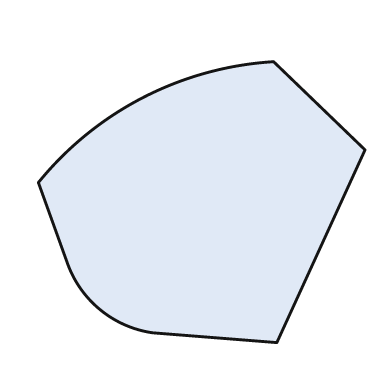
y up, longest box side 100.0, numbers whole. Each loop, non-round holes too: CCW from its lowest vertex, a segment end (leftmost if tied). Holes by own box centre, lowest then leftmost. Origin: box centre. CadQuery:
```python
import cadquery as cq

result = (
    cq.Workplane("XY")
    .moveTo(23.0, -43.0)
    .lineTo(50.0, 16.0)
    .lineTo(22.0, 43.0)
    .threePointArc((-18.0, 32.0), (-50.0, 6.0))
    .lineTo(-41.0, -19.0)
    .threePointArc((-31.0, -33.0), (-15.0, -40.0))
    .close()
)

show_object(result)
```